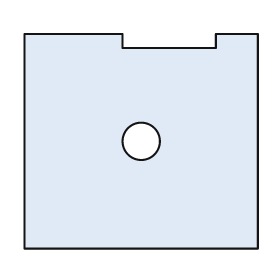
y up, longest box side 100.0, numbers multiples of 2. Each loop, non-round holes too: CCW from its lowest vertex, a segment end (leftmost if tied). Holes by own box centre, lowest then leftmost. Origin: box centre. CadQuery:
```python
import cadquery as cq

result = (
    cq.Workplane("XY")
    .moveTo(-50.0, -46.0)
    .lineTo(50.0, -46.0)
    .lineTo(50.0, 46.0)
    .lineTo(32.0, 46.0)
    .lineTo(32.0, 40.0)
    .lineTo(-8.0, 40.0)
    .lineTo(-8.0, 46.0)
    .lineTo(-50.0, 46.0)
    .close()
    .moveTo(0.0, 0.0)
    .circle(8.0)
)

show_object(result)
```